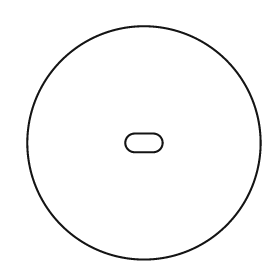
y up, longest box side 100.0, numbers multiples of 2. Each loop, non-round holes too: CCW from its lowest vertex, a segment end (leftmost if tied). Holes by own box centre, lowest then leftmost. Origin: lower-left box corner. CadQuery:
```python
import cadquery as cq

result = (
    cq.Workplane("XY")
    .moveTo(50.0, 50.0)
    .circle(50.0)
    .moveTo(46.0, 46.0)
    .lineTo(54.0, 46.0)
    .threePointArc((58.0, 50.0), (54.0, 54.0))
    .lineTo(46.0, 54.0)
    .threePointArc((42.0, 50.0), (46.0, 46.0))
    .close()
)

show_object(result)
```